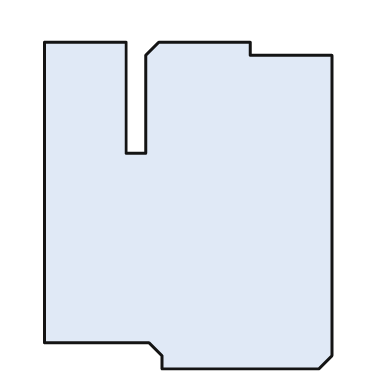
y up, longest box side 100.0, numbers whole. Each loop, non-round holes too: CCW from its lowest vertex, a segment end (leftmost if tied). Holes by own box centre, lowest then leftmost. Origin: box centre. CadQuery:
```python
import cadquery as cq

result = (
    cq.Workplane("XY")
    .moveTo(-8.0, -50.0)
    .lineTo(40.0, -50.0)
    .lineTo(44.0, -46.0)
    .lineTo(44.0, 46.0)
    .lineTo(19.0, 46.0)
    .lineTo(19.0, 50.0)
    .lineTo(-9.0, 50.0)
    .lineTo(-13.0, 46.0)
    .lineTo(-13.0, 16.0)
    .lineTo(-19.0, 16.0)
    .lineTo(-19.0, 50.0)
    .lineTo(-44.0, 50.0)
    .lineTo(-44.0, -42.0)
    .lineTo(-12.0, -42.0)
    .lineTo(-8.0, -46.0)
    .close()
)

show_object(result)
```